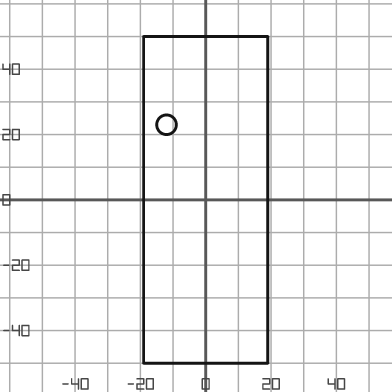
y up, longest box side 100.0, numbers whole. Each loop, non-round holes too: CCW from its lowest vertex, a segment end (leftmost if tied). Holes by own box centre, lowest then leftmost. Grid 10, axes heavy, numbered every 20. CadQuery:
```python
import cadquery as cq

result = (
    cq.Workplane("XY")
    .moveTo(-19.0, -50.0)
    .lineTo(19.0, -50.0)
    .lineTo(19.0, 50.0)
    .lineTo(-19.0, 50.0)
    .close()
    .moveTo(-12.0, 23.0)
    .circle(3.0)
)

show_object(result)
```